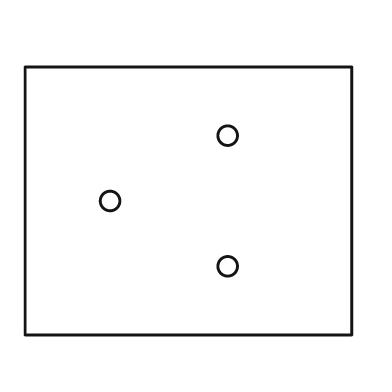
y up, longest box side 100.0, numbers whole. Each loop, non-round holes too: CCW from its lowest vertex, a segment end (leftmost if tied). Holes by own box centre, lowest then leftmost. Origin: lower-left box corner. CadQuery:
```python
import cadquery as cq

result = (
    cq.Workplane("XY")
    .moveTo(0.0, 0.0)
    .lineTo(100.0, 0.0)
    .lineTo(100.0, 82.0)
    .lineTo(0.0, 82.0)
    .close()
    .moveTo(62.0, 21.0)
    .circle(3.0)
    .moveTo(26.0, 41.0)
    .circle(3.0)
    .moveTo(62.0, 61.0)
    .circle(3.0)
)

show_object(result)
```